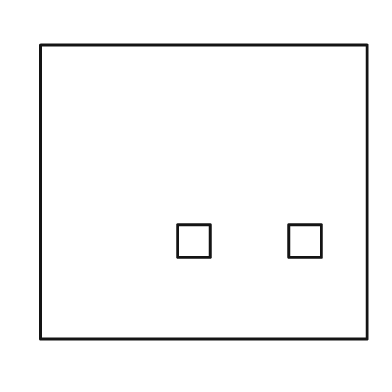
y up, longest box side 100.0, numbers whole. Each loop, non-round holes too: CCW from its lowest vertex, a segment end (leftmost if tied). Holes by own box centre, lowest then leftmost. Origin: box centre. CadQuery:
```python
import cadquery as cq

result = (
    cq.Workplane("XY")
    .moveTo(-50.0, -45.0)
    .lineTo(50.0, -45.0)
    .lineTo(50.0, 45.0)
    .lineTo(-50.0, 45.0)
    .close()
    .moveTo(-8.0, -20.0)
    .lineTo(2.0, -20.0)
    .lineTo(2.0, -10.0)
    .lineTo(-8.0, -10.0)
    .close()
    .moveTo(26.0, -20.0)
    .lineTo(36.0, -20.0)
    .lineTo(36.0, -10.0)
    .lineTo(26.0, -10.0)
    .close()
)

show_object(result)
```